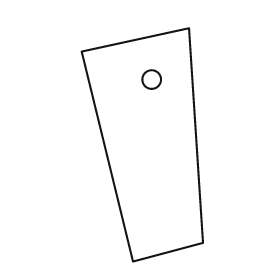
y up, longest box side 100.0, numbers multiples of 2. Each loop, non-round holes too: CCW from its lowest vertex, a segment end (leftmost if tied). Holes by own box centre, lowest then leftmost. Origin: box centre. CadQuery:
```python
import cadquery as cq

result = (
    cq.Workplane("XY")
    .moveTo(-4.0, -50.0)
    .lineTo(26.0, -42.0)
    .lineTo(20.0, 50.0)
    .lineTo(-26.0, 40.0)
    .close()
    .moveTo(4.0, 28.0)
    .circle(4.0)
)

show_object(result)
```